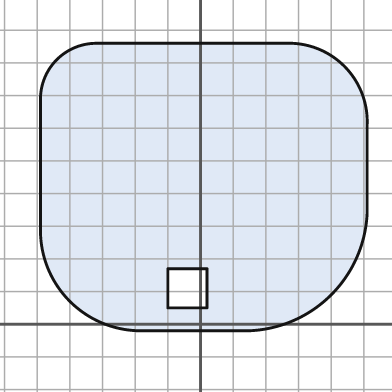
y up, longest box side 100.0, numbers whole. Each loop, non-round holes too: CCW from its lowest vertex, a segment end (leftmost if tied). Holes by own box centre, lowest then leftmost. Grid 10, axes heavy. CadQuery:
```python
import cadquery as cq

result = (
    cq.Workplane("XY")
    .moveTo(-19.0, -2.0)
    .lineTo(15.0, -2.0)
    .threePointArc((40.0, 9.0), (51.0, 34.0))
    .lineTo(51.0, 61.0)
    .threePointArc((44.0, 79.0), (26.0, 86.0))
    .lineTo(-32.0, 86.0)
    .threePointArc((-44.0, 81.0), (-49.0, 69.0))
    .lineTo(-49.0, 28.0)
    .threePointArc((-40.0, 7.0), (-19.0, -2.0))
    .close()
    .moveTo(-10.0, 5.0)
    .lineTo(2.0, 5.0)
    .lineTo(2.0, 17.0)
    .lineTo(-10.0, 17.0)
    .close()
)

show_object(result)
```